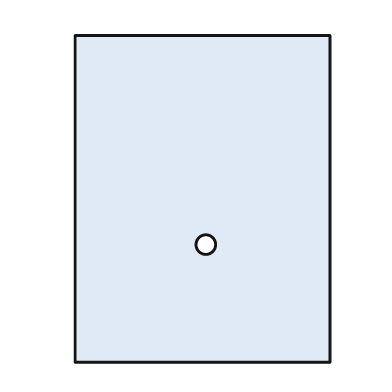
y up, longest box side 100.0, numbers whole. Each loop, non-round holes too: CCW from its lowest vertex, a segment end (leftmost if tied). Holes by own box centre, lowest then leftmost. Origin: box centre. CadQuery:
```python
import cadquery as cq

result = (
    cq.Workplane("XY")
    .moveTo(-39.0, -50.0)
    .lineTo(39.0, -50.0)
    .lineTo(39.0, 50.0)
    .lineTo(-39.0, 50.0)
    .close()
    .moveTo(1.0, -14.0)
    .circle(3.0)
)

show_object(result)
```